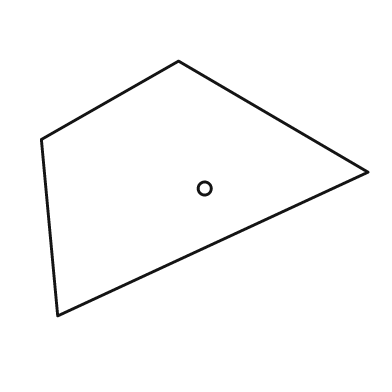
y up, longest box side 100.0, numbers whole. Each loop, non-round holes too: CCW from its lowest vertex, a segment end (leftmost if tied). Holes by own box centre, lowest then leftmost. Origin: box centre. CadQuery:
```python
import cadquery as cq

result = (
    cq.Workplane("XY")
    .moveTo(-45.0, -39.0)
    .lineTo(50.0, 5.0)
    .lineTo(-8.0, 39.0)
    .lineTo(-50.0, 15.0)
    .close()
    .moveTo(0.0, 0.0)
    .circle(2.0)
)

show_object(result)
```